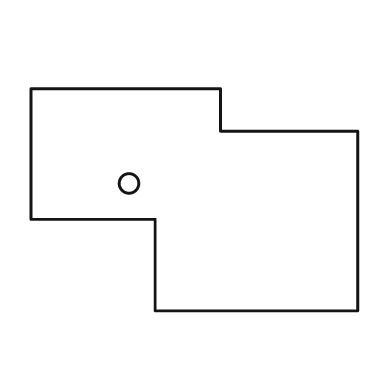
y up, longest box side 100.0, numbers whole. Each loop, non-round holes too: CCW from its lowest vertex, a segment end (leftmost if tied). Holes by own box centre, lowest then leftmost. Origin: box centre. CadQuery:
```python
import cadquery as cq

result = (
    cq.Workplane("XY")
    .moveTo(-12.0, -34.0)
    .lineTo(50.0, -34.0)
    .lineTo(50.0, 21.0)
    .lineTo(8.0, 21.0)
    .lineTo(8.0, 34.0)
    .lineTo(-50.0, 34.0)
    .lineTo(-50.0, -6.0)
    .lineTo(-12.0, -6.0)
    .close()
    .moveTo(-20.0, 5.0)
    .circle(3.0)
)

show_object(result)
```